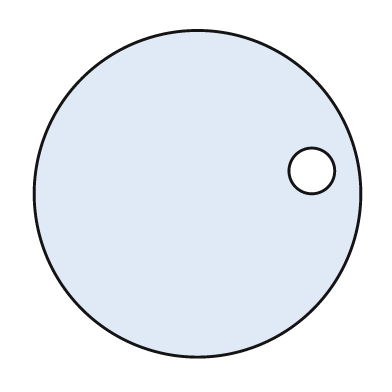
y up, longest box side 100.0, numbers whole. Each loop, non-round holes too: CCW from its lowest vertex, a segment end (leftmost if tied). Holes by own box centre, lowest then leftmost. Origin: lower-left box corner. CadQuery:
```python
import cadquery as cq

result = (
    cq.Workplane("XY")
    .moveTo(50.0, 50.0)
    .circle(50.0)
    .moveTo(85.0, 57.0)
    .circle(7.0)
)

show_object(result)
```